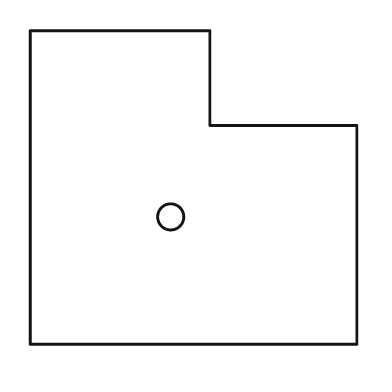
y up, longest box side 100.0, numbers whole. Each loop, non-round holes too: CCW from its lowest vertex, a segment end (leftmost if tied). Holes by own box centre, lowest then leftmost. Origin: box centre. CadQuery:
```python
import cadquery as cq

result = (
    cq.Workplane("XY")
    .moveTo(-50.0, -48.0)
    .lineTo(50.0, -48.0)
    .lineTo(50.0, 19.0)
    .lineTo(5.0, 19.0)
    .lineTo(5.0, 48.0)
    .lineTo(-50.0, 48.0)
    .close()
    .moveTo(-7.0, -9.0)
    .circle(4.0)
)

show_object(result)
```